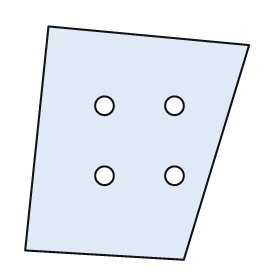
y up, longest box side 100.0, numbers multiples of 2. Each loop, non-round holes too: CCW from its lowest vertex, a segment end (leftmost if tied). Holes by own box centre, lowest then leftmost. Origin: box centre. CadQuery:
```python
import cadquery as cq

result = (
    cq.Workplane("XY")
    .moveTo(20.0, -50.0)
    .lineTo(48.0, 42.0)
    .lineTo(-38.0, 50.0)
    .lineTo(-48.0, -46.0)
    .close()
    .moveTo(-14.0, -14.0)
    .circle(4.0)
    .moveTo(16.0, -14.0)
    .circle(4.0)
    .moveTo(-14.0, 16.0)
    .circle(4.0)
    .moveTo(16.0, 16.0)
    .circle(4.0)
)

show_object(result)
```